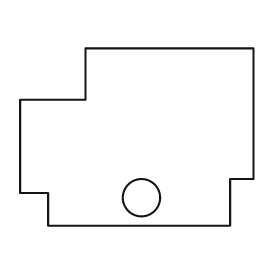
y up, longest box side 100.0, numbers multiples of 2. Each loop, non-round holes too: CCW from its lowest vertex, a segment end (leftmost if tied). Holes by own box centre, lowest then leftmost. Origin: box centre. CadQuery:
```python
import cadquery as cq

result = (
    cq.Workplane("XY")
    .moveTo(-38.0, -38.0)
    .lineTo(40.0, -38.0)
    .lineTo(40.0, -18.0)
    .lineTo(50.0, -18.0)
    .lineTo(50.0, 38.0)
    .lineTo(-22.0, 38.0)
    .lineTo(-22.0, 16.0)
    .lineTo(-50.0, 16.0)
    .lineTo(-50.0, -24.0)
    .lineTo(-38.0, -24.0)
    .close()
    .moveTo(2.0, -26.0)
    .circle(8.0)
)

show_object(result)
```